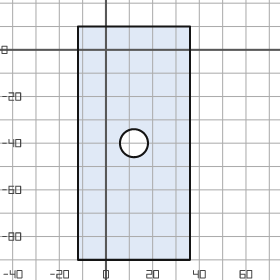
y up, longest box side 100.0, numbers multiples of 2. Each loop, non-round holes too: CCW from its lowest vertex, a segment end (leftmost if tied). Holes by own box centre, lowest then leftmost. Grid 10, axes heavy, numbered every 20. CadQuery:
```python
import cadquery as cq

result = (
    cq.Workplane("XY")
    .moveTo(-12.0, -90.0)
    .lineTo(36.0, -90.0)
    .lineTo(36.0, 10.0)
    .lineTo(-12.0, 10.0)
    .close()
    .moveTo(12.0, -40.0)
    .circle(6.0)
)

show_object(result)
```